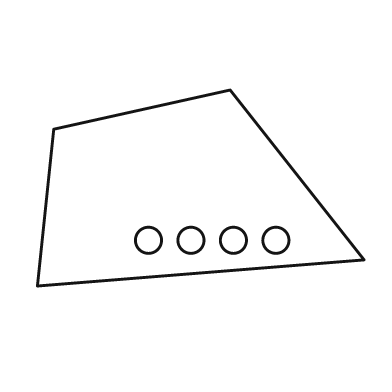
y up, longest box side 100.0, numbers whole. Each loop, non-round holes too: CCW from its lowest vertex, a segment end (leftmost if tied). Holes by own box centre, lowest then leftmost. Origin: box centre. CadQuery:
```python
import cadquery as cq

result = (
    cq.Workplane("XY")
    .moveTo(-50.0, -30.0)
    .lineTo(50.0, -22.0)
    .lineTo(9.0, 30.0)
    .lineTo(-45.0, 18.0)
    .close()
    .moveTo(-16.0, -16.0)
    .circle(4.0)
    .moveTo(-3.0, -16.0)
    .circle(4.0)
    .moveTo(10.0, -16.0)
    .circle(4.0)
    .moveTo(23.0, -16.0)
    .circle(4.0)
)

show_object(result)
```